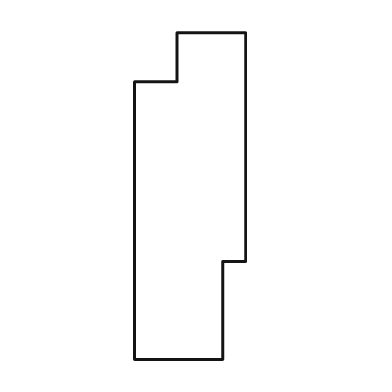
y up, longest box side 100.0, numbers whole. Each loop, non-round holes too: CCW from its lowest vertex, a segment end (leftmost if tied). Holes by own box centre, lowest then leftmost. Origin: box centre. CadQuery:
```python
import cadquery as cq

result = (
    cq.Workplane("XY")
    .moveTo(-17.0, -50.0)
    .lineTo(10.0, -50.0)
    .lineTo(10.0, -20.0)
    .lineTo(17.0, -20.0)
    .lineTo(17.0, 50.0)
    .lineTo(-4.0, 50.0)
    .lineTo(-4.0, 35.0)
    .lineTo(-17.0, 35.0)
    .close()
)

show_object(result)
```